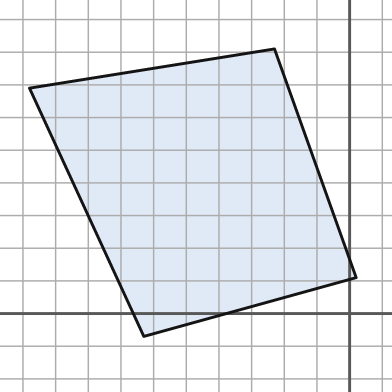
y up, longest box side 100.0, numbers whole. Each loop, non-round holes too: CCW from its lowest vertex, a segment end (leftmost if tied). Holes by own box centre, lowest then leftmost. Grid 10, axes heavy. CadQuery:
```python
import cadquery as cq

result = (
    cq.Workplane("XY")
    .moveTo(-63.0, -7.0)
    .lineTo(2.0, 11.0)
    .lineTo(-23.0, 81.0)
    .lineTo(-98.0, 69.0)
    .close()
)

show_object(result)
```